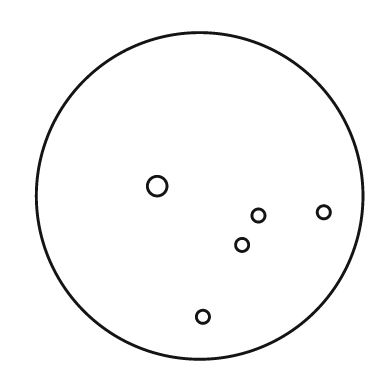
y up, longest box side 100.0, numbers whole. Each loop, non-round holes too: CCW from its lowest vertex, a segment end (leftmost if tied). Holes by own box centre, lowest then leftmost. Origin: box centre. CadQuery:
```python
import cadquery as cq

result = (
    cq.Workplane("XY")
    .moveTo(0.0, 0.0)
    .circle(50.0)
    .moveTo(1.0, -37.0)
    .circle(2.0)
    .moveTo(13.0, -15.0)
    .circle(2.0)
    .moveTo(18.0, -6.0)
    .circle(2.0)
    .moveTo(38.0, -5.0)
    .circle(2.0)
    .moveTo(-13.0, 3.0)
    .circle(3.0)
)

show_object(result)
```